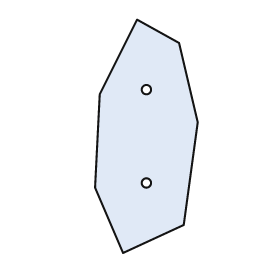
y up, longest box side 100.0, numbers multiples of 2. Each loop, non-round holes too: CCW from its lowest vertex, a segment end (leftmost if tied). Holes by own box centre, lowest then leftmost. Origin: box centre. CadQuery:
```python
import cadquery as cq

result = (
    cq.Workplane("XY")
    .moveTo(-10.0, -50.0)
    .lineTo(16.0, -38.0)
    .lineTo(22.0, 6.0)
    .lineTo(14.0, 40.0)
    .lineTo(-4.0, 50.0)
    .lineTo(-20.0, 18.0)
    .lineTo(-22.0, -22.0)
    .close()
    .moveTo(0.0, -20.0)
    .circle(2.0)
    .moveTo(0.0, 20.0)
    .circle(2.0)
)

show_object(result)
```